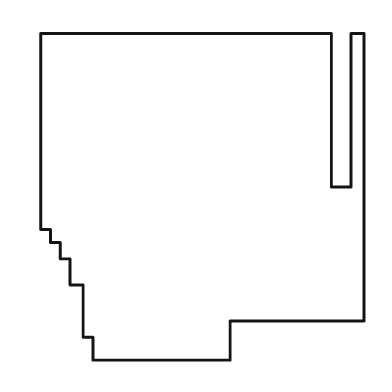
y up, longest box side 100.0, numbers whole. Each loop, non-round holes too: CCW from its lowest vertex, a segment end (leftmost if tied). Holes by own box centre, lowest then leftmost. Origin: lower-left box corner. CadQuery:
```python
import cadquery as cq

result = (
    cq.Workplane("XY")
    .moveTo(16.0, 0.0)
    .lineTo(58.0, 0.0)
    .lineTo(58.0, 12.0)
    .lineTo(99.0, 12.0)
    .lineTo(99.0, 100.0)
    .lineTo(95.0, 100.0)
    .lineTo(95.0, 53.0)
    .lineTo(89.0, 53.0)
    .lineTo(89.0, 100.0)
    .lineTo(0.0, 100.0)
    .lineTo(0.0, 40.0)
    .lineTo(3.0, 40.0)
    .lineTo(3.0, 36.0)
    .lineTo(6.0, 36.0)
    .lineTo(6.0, 31.0)
    .lineTo(9.0, 31.0)
    .lineTo(9.0, 23.0)
    .lineTo(13.0, 23.0)
    .lineTo(13.0, 7.0)
    .lineTo(16.0, 7.0)
    .close()
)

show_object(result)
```